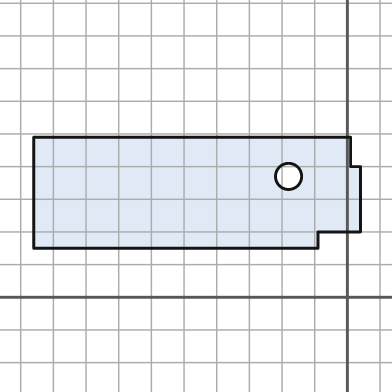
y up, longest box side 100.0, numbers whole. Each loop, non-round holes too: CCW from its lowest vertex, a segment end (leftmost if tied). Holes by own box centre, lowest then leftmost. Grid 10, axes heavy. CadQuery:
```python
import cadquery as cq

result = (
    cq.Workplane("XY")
    .moveTo(-96.0, 15.0)
    .lineTo(-9.0, 15.0)
    .lineTo(-9.0, 20.0)
    .lineTo(4.0, 20.0)
    .lineTo(4.0, 40.0)
    .lineTo(1.0, 40.0)
    .lineTo(1.0, 49.0)
    .lineTo(-96.0, 49.0)
    .close()
    .moveTo(-18.0, 37.0)
    .circle(4.0)
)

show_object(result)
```